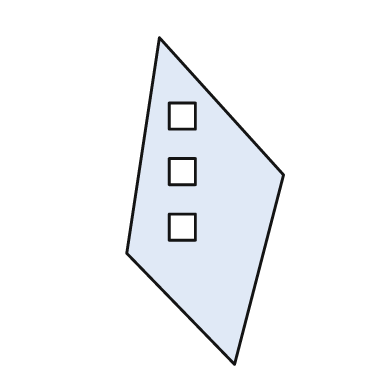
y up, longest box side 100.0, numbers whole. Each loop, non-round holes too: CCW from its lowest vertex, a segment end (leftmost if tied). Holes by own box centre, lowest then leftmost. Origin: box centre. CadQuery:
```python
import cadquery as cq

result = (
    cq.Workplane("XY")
    .moveTo(9.0, -50.0)
    .lineTo(24.0, 8.0)
    .lineTo(-14.0, 50.0)
    .lineTo(-24.0, -16.0)
    .close()
    .moveTo(-11.0, -12.0)
    .lineTo(-3.0, -12.0)
    .lineTo(-3.0, -4.0)
    .lineTo(-11.0, -4.0)
    .close()
    .moveTo(-11.0, 5.0)
    .lineTo(-3.0, 5.0)
    .lineTo(-3.0, 13.0)
    .lineTo(-11.0, 13.0)
    .close()
    .moveTo(-11.0, 22.0)
    .lineTo(-3.0, 22.0)
    .lineTo(-3.0, 30.0)
    .lineTo(-11.0, 30.0)
    .close()
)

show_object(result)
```